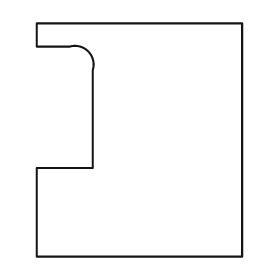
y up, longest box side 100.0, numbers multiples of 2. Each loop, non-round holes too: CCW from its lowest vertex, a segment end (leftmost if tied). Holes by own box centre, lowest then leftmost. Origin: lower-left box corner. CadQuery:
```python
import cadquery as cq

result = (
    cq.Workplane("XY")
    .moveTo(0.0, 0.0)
    .lineTo(88.0, 0.0)
    .lineTo(88.0, 100.0)
    .lineTo(0.0, 100.0)
    .lineTo(0.0, 90.0)
    .lineTo(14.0, 90.0)
    .threePointArc((22.0, 88.0), (24.0, 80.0))
    .lineTo(24.0, 38.0)
    .lineTo(0.0, 38.0)
    .close()
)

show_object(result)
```